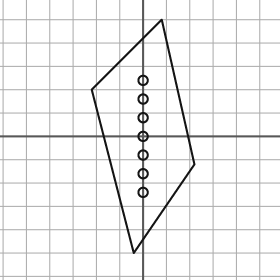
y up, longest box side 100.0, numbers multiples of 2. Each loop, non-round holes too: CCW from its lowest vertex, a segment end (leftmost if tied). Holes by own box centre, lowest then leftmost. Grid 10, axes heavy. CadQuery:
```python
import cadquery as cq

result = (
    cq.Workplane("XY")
    .moveTo(-4.0, -50.0)
    .lineTo(22.0, -12.0)
    .lineTo(8.0, 50.0)
    .lineTo(-22.0, 20.0)
    .close()
    .moveTo(0.0, -24.0)
    .circle(2.0)
    .moveTo(0.0, -16.0)
    .circle(2.0)
    .moveTo(0.0, -8.0)
    .circle(2.0)
    .moveTo(0.0, 0.0)
    .circle(2.0)
    .moveTo(0.0, 8.0)
    .circle(2.0)
    .moveTo(0.0, 16.0)
    .circle(2.0)
    .moveTo(0.0, 24.0)
    .circle(2.0)
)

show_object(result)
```